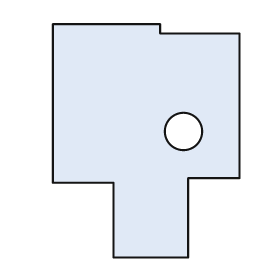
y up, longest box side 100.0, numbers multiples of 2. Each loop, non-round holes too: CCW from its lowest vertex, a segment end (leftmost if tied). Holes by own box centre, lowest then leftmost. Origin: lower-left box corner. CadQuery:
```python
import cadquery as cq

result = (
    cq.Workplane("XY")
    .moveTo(26.0, 0.0)
    .lineTo(58.0, 0.0)
    .lineTo(58.0, 34.0)
    .lineTo(80.0, 34.0)
    .lineTo(80.0, 96.0)
    .lineTo(46.0, 96.0)
    .lineTo(46.0, 100.0)
    .lineTo(0.0, 100.0)
    .lineTo(0.0, 32.0)
    .lineTo(26.0, 32.0)
    .close()
    .moveTo(56.0, 54.0)
    .circle(8.0)
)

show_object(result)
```